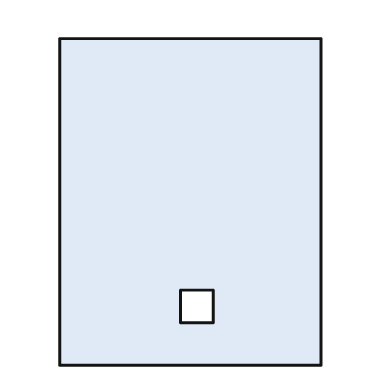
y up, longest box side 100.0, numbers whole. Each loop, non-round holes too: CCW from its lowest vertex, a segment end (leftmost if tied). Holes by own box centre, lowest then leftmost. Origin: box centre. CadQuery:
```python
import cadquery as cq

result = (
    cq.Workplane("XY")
    .moveTo(-40.0, -50.0)
    .lineTo(40.0, -50.0)
    .lineTo(40.0, 50.0)
    .lineTo(-40.0, 50.0)
    .close()
    .moveTo(-3.0, -37.0)
    .lineTo(7.0, -37.0)
    .lineTo(7.0, -27.0)
    .lineTo(-3.0, -27.0)
    .close()
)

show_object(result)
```